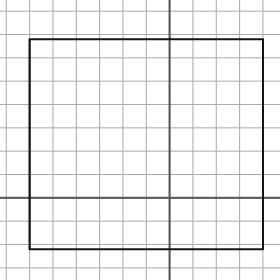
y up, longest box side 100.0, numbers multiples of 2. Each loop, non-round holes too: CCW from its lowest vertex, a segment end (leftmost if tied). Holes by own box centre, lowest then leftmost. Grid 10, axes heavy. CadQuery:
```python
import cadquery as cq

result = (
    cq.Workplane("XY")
    .moveTo(-60.0, -22.0)
    .lineTo(40.0, -22.0)
    .lineTo(40.0, 68.0)
    .lineTo(-60.0, 68.0)
    .close()
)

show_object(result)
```